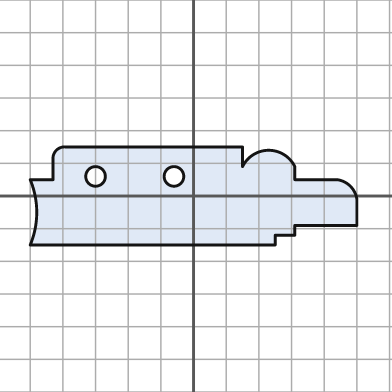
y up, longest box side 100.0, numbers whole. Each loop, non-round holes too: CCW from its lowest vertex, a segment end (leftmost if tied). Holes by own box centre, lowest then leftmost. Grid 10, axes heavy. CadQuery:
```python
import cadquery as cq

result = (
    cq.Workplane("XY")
    .moveTo(-50.0, -15.0)
    .lineTo(25.0, -15.0)
    .lineTo(25.0, -12.0)
    .lineTo(31.0, -12.0)
    .lineTo(31.0, -9.0)
    .lineTo(50.0, -9.0)
    .lineTo(50.0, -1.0)
    .threePointArc((48.0, 3.0), (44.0, 5.0))
    .lineTo(31.0, 5.0)
    .lineTo(31.0, 9.0)
    .threePointArc((23.0, 14.0), (15.0, 9.0))
    .lineTo(15.0, 15.0)
    .lineTo(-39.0, 15.0)
    .threePointArc((-42.0, 14.0), (-43.0, 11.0))
    .lineTo(-43.0, 5.0)
    .lineTo(-50.0, 5.0)
    .threePointArc((-48.0, -5.0), (-50.0, -15.0))
    .close()
    .moveTo(-30.0, 6.0)
    .circle(3.0)
    .moveTo(-6.0, 6.0)
    .circle(3.0)
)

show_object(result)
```